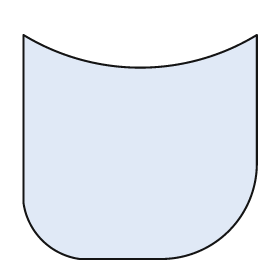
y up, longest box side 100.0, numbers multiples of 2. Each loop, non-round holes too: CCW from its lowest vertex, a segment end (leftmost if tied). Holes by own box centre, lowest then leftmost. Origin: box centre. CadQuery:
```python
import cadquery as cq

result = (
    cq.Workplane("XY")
    .moveTo(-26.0, -48.0)
    .lineTo(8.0, -48.0)
    .threePointArc((38.0, -36.0), (50.0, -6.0))
    .lineTo(50.0, 48.0)
    .threePointArc((0.0, 34.0), (-50.0, 48.0))
    .lineTo(-50.0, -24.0)
    .threePointArc((-42.0, -40.0), (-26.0, -48.0))
    .close()
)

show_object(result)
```